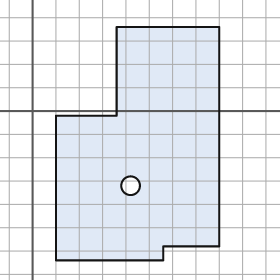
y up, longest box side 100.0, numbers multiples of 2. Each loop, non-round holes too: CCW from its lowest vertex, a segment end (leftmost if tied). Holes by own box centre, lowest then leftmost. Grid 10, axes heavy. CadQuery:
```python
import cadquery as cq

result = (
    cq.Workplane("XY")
    .moveTo(10.0, -64.0)
    .lineTo(56.0, -64.0)
    .lineTo(56.0, -58.0)
    .lineTo(80.0, -58.0)
    .lineTo(80.0, 36.0)
    .lineTo(36.0, 36.0)
    .lineTo(36.0, -2.0)
    .lineTo(10.0, -2.0)
    .close()
    .moveTo(42.0, -32.0)
    .circle(4.0)
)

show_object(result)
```